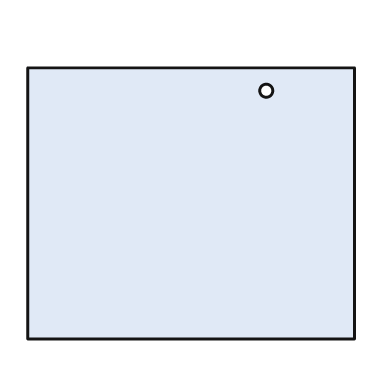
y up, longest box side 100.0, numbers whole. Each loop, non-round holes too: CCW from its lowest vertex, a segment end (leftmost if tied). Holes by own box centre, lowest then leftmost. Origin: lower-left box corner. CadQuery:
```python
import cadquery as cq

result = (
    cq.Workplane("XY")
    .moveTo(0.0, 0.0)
    .lineTo(100.0, 0.0)
    .lineTo(100.0, 83.0)
    .lineTo(0.0, 83.0)
    .close()
    .moveTo(73.0, 76.0)
    .circle(2.0)
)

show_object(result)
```